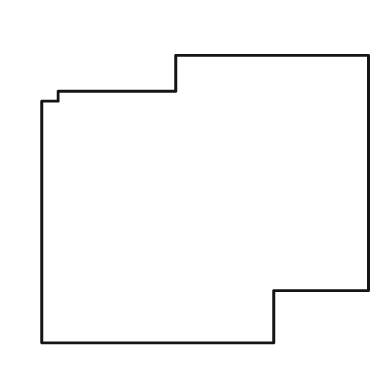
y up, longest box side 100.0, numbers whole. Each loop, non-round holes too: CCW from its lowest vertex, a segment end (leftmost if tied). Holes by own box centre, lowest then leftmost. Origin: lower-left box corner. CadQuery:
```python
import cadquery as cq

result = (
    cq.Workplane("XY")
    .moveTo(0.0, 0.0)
    .lineTo(71.0, 0.0)
    .lineTo(71.0, 16.0)
    .lineTo(100.0, 16.0)
    .lineTo(100.0, 88.0)
    .lineTo(41.0, 88.0)
    .lineTo(41.0, 77.0)
    .lineTo(5.0, 77.0)
    .lineTo(5.0, 74.0)
    .lineTo(0.0, 74.0)
    .close()
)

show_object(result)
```